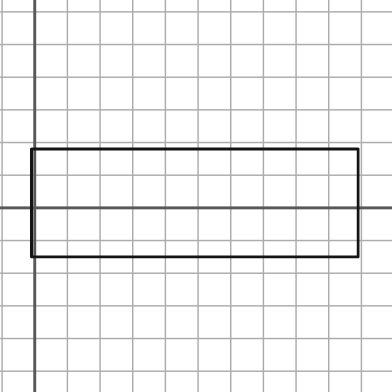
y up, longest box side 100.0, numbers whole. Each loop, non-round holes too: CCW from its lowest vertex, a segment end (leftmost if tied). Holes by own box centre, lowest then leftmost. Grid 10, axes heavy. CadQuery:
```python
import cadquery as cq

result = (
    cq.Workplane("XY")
    .moveTo(-1.0, -15.0)
    .lineTo(99.0, -15.0)
    .lineTo(99.0, 18.0)
    .lineTo(-1.0, 18.0)
    .close()
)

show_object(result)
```